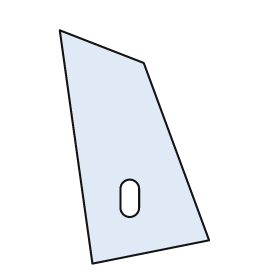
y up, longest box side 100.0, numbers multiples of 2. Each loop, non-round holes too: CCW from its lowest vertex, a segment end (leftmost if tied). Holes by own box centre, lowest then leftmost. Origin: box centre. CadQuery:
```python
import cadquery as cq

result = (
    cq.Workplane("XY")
    .moveTo(-18.0, -50.0)
    .lineTo(32.0, -40.0)
    .lineTo(4.0, 36.0)
    .lineTo(-32.0, 50.0)
    .close()
    .moveTo(-6.0, -26.0)
    .threePointArc((-2.0, -30.0), (2.0, -26.0))
    .lineTo(2.0, -18.0)
    .threePointArc((-2.0, -14.0), (-6.0, -18.0))
    .close()
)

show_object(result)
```